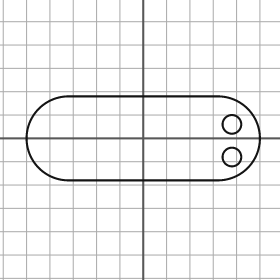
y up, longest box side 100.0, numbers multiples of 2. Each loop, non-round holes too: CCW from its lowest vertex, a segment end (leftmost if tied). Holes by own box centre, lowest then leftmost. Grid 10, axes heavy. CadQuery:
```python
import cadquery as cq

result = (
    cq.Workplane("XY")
    .moveTo(-32.0, -18.0)
    .lineTo(32.0, -18.0)
    .threePointArc((50.0, 0.0), (32.0, 18.0))
    .lineTo(-32.0, 18.0)
    .threePointArc((-50.0, 0.0), (-32.0, -18.0))
    .close()
    .moveTo(38.0, -8.0)
    .circle(4.0)
    .moveTo(38.0, 6.0)
    .circle(4.0)
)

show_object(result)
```